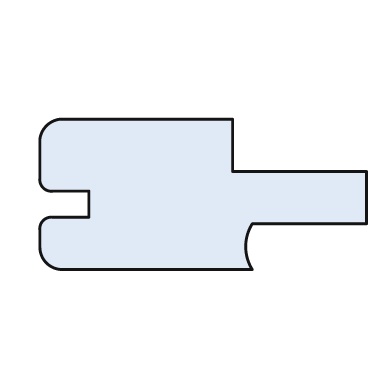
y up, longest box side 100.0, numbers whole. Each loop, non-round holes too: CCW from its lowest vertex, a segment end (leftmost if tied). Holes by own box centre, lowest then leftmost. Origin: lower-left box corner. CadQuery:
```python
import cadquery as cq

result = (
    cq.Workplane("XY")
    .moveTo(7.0, 0.0)
    .lineTo(65.0, 0.0)
    .threePointArc((63.0, 7.0), (65.0, 14.0))
    .lineTo(100.0, 14.0)
    .lineTo(100.0, 30.0)
    .lineTo(59.0, 30.0)
    .lineTo(59.0, 46.0)
    .lineTo(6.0, 46.0)
    .threePointArc((2.0, 44.0), (0.0, 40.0))
    .lineTo(0.0, 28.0)
    .threePointArc((1.0, 25.0), (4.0, 24.0))
    .lineTo(15.0, 24.0)
    .lineTo(15.0, 16.0)
    .lineTo(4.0, 16.0)
    .threePointArc((1.0, 15.0), (0.0, 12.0))
    .lineTo(0.0, 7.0)
    .threePointArc((2.0, 2.0), (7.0, 0.0))
    .close()
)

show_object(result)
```